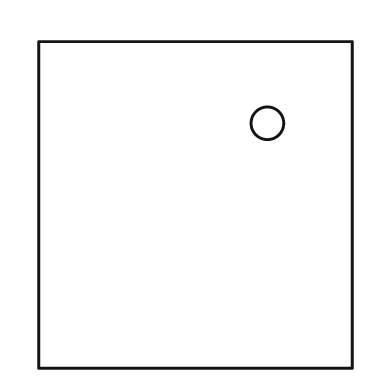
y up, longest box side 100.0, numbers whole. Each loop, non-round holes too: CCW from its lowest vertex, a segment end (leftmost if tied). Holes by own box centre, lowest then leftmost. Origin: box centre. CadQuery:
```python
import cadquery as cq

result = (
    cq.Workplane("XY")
    .moveTo(-48.0, -50.0)
    .lineTo(48.0, -50.0)
    .lineTo(48.0, 50.0)
    .lineTo(-48.0, 50.0)
    .close()
    .moveTo(22.0, 25.0)
    .circle(5.0)
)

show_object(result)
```